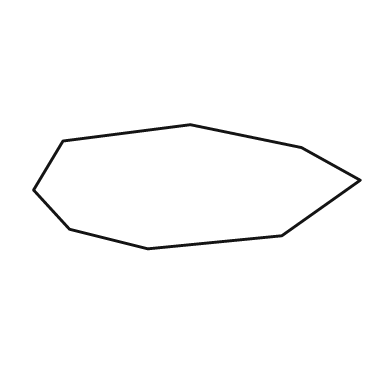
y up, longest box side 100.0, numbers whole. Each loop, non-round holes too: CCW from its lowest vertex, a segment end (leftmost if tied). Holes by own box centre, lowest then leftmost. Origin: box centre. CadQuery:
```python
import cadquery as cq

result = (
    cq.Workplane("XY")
    .moveTo(-15.0, -19.0)
    .lineTo(26.0, -15.0)
    .lineTo(50.0, 2.0)
    .lineTo(32.0, 12.0)
    .lineTo(-2.0, 19.0)
    .lineTo(-41.0, 14.0)
    .lineTo(-50.0, -1.0)
    .lineTo(-39.0, -13.0)
    .close()
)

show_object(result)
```